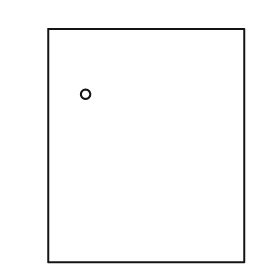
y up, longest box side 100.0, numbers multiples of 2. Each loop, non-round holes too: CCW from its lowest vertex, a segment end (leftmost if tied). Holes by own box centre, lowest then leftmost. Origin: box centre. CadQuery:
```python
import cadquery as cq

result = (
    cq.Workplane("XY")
    .moveTo(-42.0, -50.0)
    .lineTo(42.0, -50.0)
    .lineTo(42.0, 50.0)
    .lineTo(-42.0, 50.0)
    .close()
    .moveTo(-26.0, 22.0)
    .circle(2.0)
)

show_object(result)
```